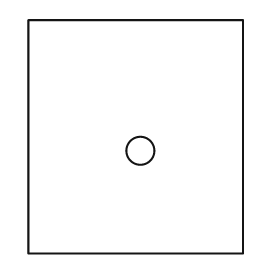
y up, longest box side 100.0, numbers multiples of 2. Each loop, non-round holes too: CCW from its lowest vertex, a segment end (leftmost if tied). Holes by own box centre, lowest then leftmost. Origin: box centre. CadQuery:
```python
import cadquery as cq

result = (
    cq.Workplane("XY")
    .moveTo(-46.0, -50.0)
    .lineTo(46.0, -50.0)
    .lineTo(46.0, 50.0)
    .lineTo(-46.0, 50.0)
    .close()
    .moveTo(2.0, -6.0)
    .circle(6.0)
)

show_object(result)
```